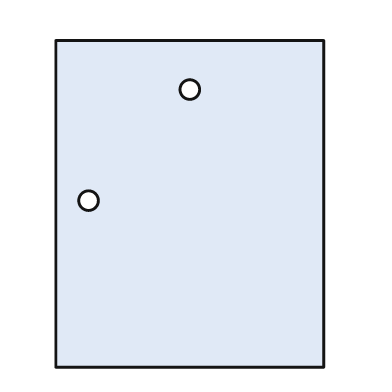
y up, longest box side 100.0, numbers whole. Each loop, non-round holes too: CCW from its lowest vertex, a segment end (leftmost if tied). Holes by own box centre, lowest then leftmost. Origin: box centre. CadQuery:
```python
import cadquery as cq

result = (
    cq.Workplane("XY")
    .moveTo(-41.0, -50.0)
    .lineTo(41.0, -50.0)
    .lineTo(41.0, 50.0)
    .lineTo(-41.0, 50.0)
    .close()
    .moveTo(-31.0, 1.0)
    .circle(3.0)
    .moveTo(0.0, 35.0)
    .circle(3.0)
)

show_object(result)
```